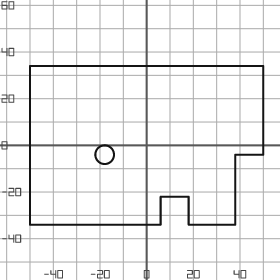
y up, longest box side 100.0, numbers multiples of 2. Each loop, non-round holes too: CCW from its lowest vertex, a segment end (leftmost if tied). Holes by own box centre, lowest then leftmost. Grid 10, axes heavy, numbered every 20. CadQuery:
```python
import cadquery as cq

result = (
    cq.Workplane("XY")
    .moveTo(-50.0, -34.0)
    .lineTo(6.0, -34.0)
    .lineTo(6.0, -22.0)
    .lineTo(18.0, -22.0)
    .lineTo(18.0, -34.0)
    .lineTo(38.0, -34.0)
    .lineTo(38.0, -4.0)
    .lineTo(50.0, -4.0)
    .lineTo(50.0, 34.0)
    .lineTo(-50.0, 34.0)
    .close()
    .moveTo(-18.0, -4.0)
    .circle(4.0)
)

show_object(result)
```